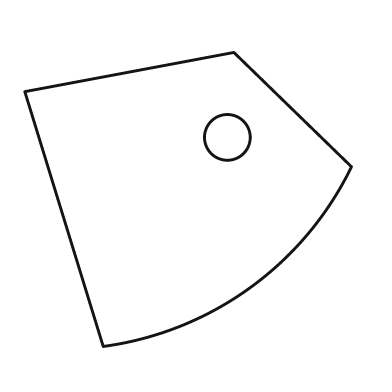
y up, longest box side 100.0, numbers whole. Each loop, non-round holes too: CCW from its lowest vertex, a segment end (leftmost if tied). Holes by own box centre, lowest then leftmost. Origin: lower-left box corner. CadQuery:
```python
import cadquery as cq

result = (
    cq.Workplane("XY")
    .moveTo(24.0, 0.0)
    .threePointArc((69.0, 18.0), (100.0, 55.0))
    .lineTo(64.0, 90.0)
    .lineTo(0.0, 78.0)
    .close()
    .moveTo(62.0, 64.0)
    .circle(7.0)
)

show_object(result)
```